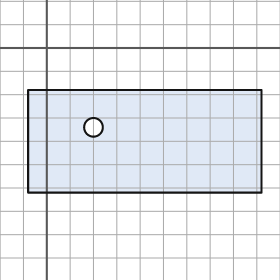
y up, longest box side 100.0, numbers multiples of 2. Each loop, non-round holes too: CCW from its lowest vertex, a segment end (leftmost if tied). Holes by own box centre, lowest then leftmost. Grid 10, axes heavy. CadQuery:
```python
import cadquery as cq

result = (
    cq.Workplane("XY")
    .moveTo(-8.0, -62.0)
    .lineTo(92.0, -62.0)
    .lineTo(92.0, -18.0)
    .lineTo(-8.0, -18.0)
    .close()
    .moveTo(20.0, -34.0)
    .circle(4.0)
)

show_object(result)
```